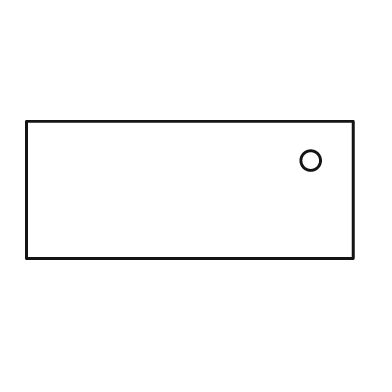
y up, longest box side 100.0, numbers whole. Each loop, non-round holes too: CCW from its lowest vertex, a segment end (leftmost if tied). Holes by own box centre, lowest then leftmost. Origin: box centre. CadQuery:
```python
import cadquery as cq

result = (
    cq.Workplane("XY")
    .moveTo(-50.0, -21.0)
    .lineTo(50.0, -21.0)
    .lineTo(50.0, 21.0)
    .lineTo(-50.0, 21.0)
    .close()
    .moveTo(37.0, 9.0)
    .circle(3.0)
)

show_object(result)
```